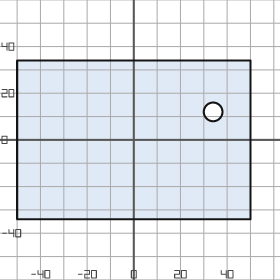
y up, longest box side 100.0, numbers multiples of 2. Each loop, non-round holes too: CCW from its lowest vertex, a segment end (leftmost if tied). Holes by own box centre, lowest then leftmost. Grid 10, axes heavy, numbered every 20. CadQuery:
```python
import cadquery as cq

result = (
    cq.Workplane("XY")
    .moveTo(-50.0, -34.0)
    .lineTo(50.0, -34.0)
    .lineTo(50.0, 34.0)
    .lineTo(-50.0, 34.0)
    .close()
    .moveTo(34.0, 12.0)
    .circle(4.0)
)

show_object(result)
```